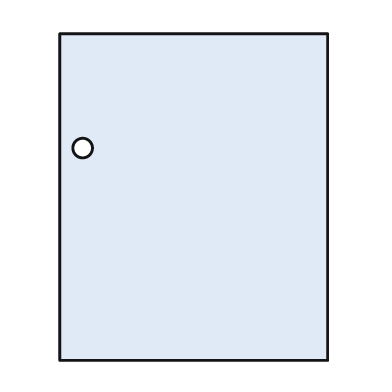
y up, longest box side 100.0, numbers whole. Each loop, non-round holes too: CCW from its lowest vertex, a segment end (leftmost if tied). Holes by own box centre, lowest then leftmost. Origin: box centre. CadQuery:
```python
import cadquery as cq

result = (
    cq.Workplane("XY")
    .moveTo(-41.0, -50.0)
    .lineTo(41.0, -50.0)
    .lineTo(41.0, 50.0)
    .lineTo(-41.0, 50.0)
    .close()
    .moveTo(-34.0, 15.0)
    .circle(3.0)
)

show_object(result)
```